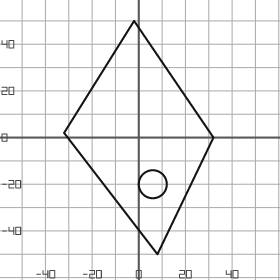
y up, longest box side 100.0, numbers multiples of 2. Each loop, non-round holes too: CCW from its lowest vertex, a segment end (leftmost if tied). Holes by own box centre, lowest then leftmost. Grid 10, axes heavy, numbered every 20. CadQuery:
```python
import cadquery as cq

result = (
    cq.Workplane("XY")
    .moveTo(8.0, -50.0)
    .lineTo(32.0, 0.0)
    .lineTo(-2.0, 50.0)
    .lineTo(-32.0, 2.0)
    .close()
    .moveTo(6.0, -20.0)
    .circle(6.0)
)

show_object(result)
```